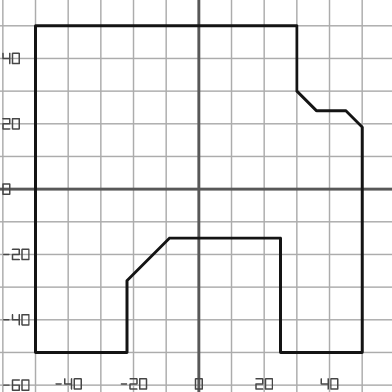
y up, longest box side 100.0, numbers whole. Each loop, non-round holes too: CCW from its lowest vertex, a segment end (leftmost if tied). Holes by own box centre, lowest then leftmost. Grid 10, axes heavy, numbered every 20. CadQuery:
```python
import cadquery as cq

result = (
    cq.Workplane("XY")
    .moveTo(-50.0, -50.0)
    .lineTo(-22.0, -50.0)
    .lineTo(-22.0, -28.0)
    .lineTo(-9.0, -15.0)
    .lineTo(25.0, -15.0)
    .lineTo(25.0, -50.0)
    .lineTo(50.0, -50.0)
    .lineTo(50.0, 19.0)
    .lineTo(45.0, 24.0)
    .lineTo(36.0, 24.0)
    .lineTo(30.0, 30.0)
    .lineTo(30.0, 50.0)
    .lineTo(-50.0, 50.0)
    .close()
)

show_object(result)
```